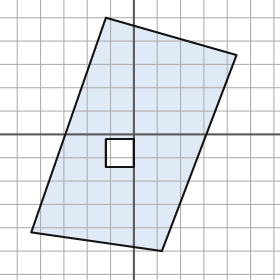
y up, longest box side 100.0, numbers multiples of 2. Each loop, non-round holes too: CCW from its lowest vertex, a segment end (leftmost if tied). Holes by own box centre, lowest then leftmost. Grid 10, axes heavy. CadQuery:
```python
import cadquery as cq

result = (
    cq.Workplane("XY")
    .moveTo(12.0, -50.0)
    .lineTo(44.0, 34.0)
    .lineTo(-12.0, 50.0)
    .lineTo(-44.0, -42.0)
    .close()
    .moveTo(-12.0, -14.0)
    .lineTo(0.0, -14.0)
    .lineTo(0.0, -2.0)
    .lineTo(-12.0, -2.0)
    .close()
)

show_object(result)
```